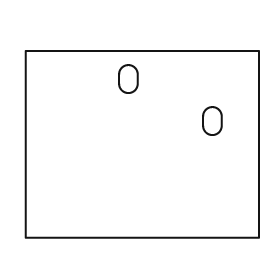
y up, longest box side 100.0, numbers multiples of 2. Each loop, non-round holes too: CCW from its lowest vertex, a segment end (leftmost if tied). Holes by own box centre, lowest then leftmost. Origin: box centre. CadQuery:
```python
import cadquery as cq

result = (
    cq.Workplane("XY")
    .moveTo(-50.0, -40.0)
    .lineTo(50.0, -40.0)
    .lineTo(50.0, 40.0)
    .lineTo(-50.0, 40.0)
    .close()
    .moveTo(26.0, 8.0)
    .threePointArc((30.0, 4.0), (34.0, 8.0))
    .lineTo(34.0, 12.0)
    .threePointArc((30.0, 16.0), (26.0, 12.0))
    .close()
    .moveTo(-10.0, 26.0)
    .threePointArc((-6.0, 22.0), (-2.0, 26.0))
    .lineTo(-2.0, 30.0)
    .threePointArc((-6.0, 34.0), (-10.0, 30.0))
    .close()
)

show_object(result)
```